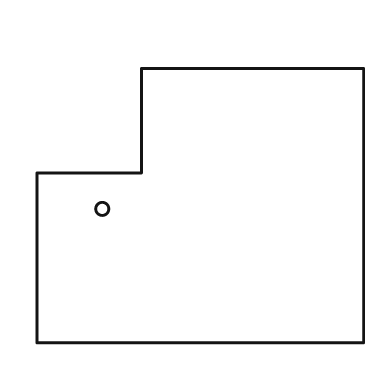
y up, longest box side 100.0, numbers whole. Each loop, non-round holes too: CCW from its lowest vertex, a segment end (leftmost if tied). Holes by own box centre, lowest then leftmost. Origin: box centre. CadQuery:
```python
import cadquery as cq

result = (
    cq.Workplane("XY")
    .moveTo(-50.0, -42.0)
    .lineTo(50.0, -42.0)
    .lineTo(50.0, 42.0)
    .lineTo(-18.0, 42.0)
    .lineTo(-18.0, 10.0)
    .lineTo(-50.0, 10.0)
    .close()
    .moveTo(-30.0, -1.0)
    .circle(2.0)
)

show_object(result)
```